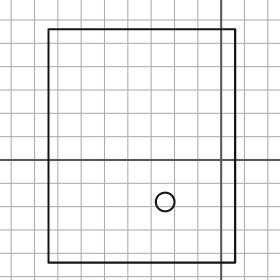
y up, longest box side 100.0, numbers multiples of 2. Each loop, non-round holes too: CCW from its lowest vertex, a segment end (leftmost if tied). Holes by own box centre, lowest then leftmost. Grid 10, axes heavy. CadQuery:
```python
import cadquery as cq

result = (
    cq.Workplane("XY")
    .moveTo(-74.0, -44.0)
    .lineTo(6.0, -44.0)
    .lineTo(6.0, 56.0)
    .lineTo(-74.0, 56.0)
    .close()
    .moveTo(-24.0, -18.0)
    .circle(4.0)
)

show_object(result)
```